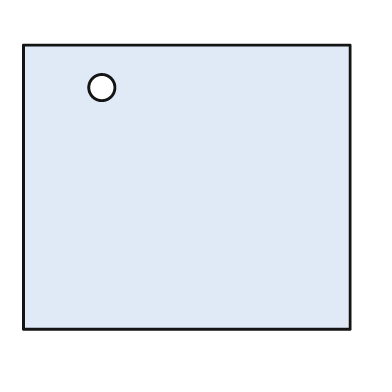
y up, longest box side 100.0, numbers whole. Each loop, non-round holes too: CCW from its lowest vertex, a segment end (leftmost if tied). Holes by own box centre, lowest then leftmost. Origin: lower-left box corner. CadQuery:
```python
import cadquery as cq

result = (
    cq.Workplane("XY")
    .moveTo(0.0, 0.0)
    .lineTo(100.0, 0.0)
    .lineTo(100.0, 87.0)
    .lineTo(0.0, 87.0)
    .close()
    .moveTo(24.0, 74.0)
    .circle(4.0)
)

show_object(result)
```